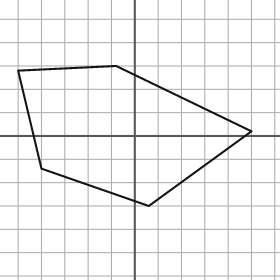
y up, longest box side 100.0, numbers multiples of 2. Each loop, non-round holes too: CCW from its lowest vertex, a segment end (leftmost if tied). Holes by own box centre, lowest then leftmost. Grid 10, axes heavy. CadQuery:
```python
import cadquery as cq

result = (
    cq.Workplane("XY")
    .moveTo(6.0, -30.0)
    .lineTo(50.0, 2.0)
    .lineTo(-8.0, 30.0)
    .lineTo(-50.0, 28.0)
    .lineTo(-40.0, -14.0)
    .close()
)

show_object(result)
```